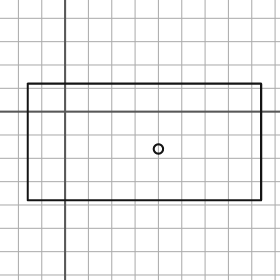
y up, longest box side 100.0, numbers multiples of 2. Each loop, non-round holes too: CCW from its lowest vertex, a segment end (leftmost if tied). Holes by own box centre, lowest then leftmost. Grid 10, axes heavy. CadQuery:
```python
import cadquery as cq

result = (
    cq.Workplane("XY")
    .moveTo(-16.0, -38.0)
    .lineTo(84.0, -38.0)
    .lineTo(84.0, 12.0)
    .lineTo(-16.0, 12.0)
    .close()
    .moveTo(40.0, -16.0)
    .circle(2.0)
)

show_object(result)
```